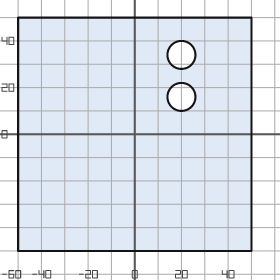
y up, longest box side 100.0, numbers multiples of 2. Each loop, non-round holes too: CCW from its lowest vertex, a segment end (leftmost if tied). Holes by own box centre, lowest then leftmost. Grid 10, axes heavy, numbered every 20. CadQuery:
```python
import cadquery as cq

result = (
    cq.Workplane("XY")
    .moveTo(-50.0, -50.0)
    .lineTo(50.0, -50.0)
    .lineTo(50.0, 50.0)
    .lineTo(-50.0, 50.0)
    .close()
    .moveTo(20.0, 16.0)
    .circle(6.0)
    .moveTo(20.0, 34.0)
    .circle(6.0)
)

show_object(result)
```